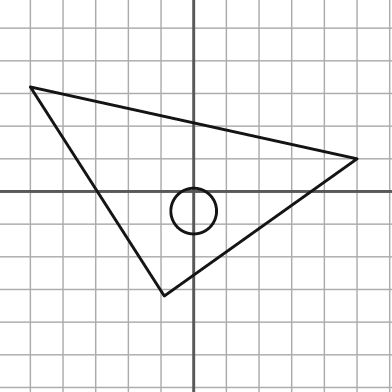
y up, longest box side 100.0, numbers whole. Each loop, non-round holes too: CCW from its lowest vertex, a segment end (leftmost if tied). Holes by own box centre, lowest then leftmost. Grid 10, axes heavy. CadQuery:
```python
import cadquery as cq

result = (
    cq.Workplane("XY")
    .moveTo(-9.0, -32.0)
    .lineTo(50.0, 10.0)
    .lineTo(-50.0, 32.0)
    .close()
    .moveTo(0.0, -6.0)
    .circle(7.0)
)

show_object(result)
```